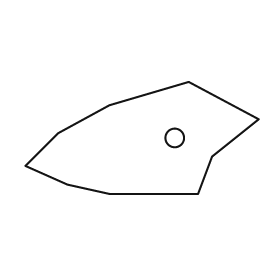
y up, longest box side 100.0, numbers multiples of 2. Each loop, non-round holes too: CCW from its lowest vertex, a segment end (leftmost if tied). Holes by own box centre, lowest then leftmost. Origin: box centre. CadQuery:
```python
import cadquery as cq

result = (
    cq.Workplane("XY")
    .moveTo(-14.0, -24.0)
    .lineTo(24.0, -24.0)
    .lineTo(30.0, -8.0)
    .lineTo(50.0, 8.0)
    .lineTo(20.0, 24.0)
    .lineTo(-14.0, 14.0)
    .lineTo(-36.0, 2.0)
    .lineTo(-50.0, -12.0)
    .lineTo(-32.0, -20.0)
    .close()
    .moveTo(14.0, 0.0)
    .circle(4.0)
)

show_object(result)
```